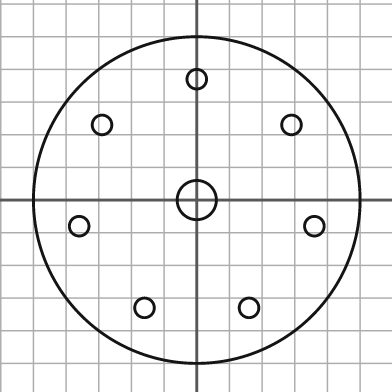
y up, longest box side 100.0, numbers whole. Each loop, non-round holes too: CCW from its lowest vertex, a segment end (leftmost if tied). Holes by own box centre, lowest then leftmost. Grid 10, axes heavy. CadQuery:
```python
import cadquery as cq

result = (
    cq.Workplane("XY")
    .moveTo(0.0, 0.0)
    .circle(50.0)
    .moveTo(-16.0, -33.0)
    .circle(3.0)
    .moveTo(16.0, -33.0)
    .circle(3.0)
    .moveTo(-36.0, -8.0)
    .circle(3.0)
    .moveTo(36.0, -8.0)
    .circle(3.0)
    .moveTo(0.0, 0.0)
    .circle(6.0)
    .moveTo(-29.0, 23.0)
    .circle(3.0)
    .moveTo(29.0, 23.0)
    .circle(3.0)
    .moveTo(0.0, 37.0)
    .circle(3.0)
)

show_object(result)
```